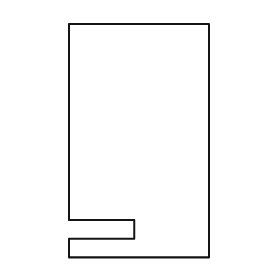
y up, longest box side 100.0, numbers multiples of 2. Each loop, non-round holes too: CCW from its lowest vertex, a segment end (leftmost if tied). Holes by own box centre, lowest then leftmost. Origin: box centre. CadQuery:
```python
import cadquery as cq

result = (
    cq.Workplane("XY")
    .moveTo(-30.0, -50.0)
    .lineTo(30.0, -50.0)
    .lineTo(30.0, 50.0)
    .lineTo(-30.0, 50.0)
    .lineTo(-30.0, -34.0)
    .lineTo(-2.0, -34.0)
    .lineTo(-2.0, -42.0)
    .lineTo(-30.0, -42.0)
    .close()
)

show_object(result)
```